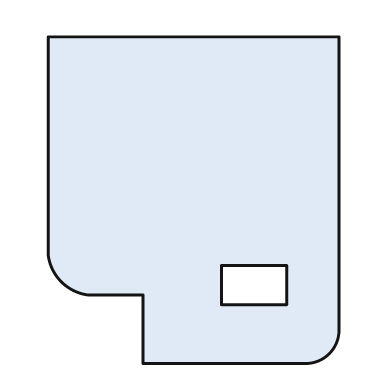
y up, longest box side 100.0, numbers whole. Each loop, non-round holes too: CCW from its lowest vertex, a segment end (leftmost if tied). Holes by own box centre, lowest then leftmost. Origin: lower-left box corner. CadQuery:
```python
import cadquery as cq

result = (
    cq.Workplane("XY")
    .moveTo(29.0, 0.0)
    .lineTo(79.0, 0.0)
    .threePointArc((86.0, 3.0), (89.0, 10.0))
    .lineTo(89.0, 100.0)
    .lineTo(0.0, 100.0)
    .lineTo(0.0, 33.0)
    .threePointArc((4.0, 25.0), (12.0, 21.0))
    .lineTo(29.0, 21.0)
    .close()
    .moveTo(53.0, 18.0)
    .lineTo(73.0, 18.0)
    .lineTo(73.0, 30.0)
    .lineTo(53.0, 30.0)
    .close()
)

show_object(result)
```